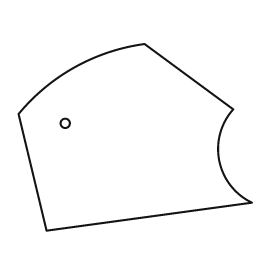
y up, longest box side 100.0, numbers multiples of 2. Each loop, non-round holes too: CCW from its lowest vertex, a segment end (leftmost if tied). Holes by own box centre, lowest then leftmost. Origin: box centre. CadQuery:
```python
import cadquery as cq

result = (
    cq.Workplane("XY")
    .moveTo(-38.0, -40.0)
    .lineTo(50.0, -28.0)
    .threePointArc((36.0, -10.0), (42.0, 12.0))
    .lineTo(4.0, 40.0)
    .threePointArc((-26.0, 30.0), (-50.0, 10.0))
    .close()
    .moveTo(-30.0, 6.0)
    .circle(2.0)
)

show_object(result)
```